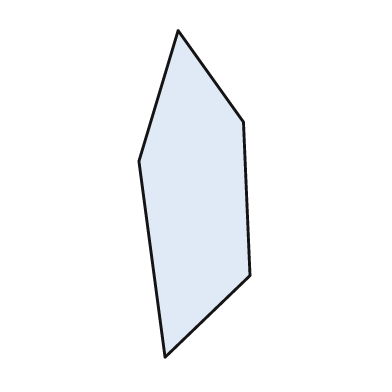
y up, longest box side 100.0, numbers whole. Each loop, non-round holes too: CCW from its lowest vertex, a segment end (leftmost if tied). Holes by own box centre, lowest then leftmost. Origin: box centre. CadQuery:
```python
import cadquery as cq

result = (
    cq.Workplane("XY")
    .moveTo(-9.0, -50.0)
    .lineTo(17.0, -25.0)
    .lineTo(15.0, 22.0)
    .lineTo(-5.0, 50.0)
    .lineTo(-17.0, 10.0)
    .close()
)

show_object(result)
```